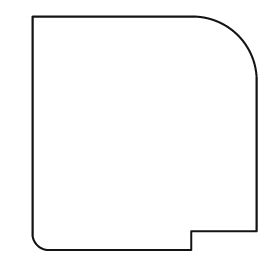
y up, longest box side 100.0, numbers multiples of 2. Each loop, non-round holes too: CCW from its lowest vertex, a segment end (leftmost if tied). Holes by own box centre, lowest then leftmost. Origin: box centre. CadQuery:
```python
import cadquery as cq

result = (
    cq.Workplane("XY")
    .moveTo(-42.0, -50.0)
    .lineTo(20.0, -50.0)
    .lineTo(20.0, -42.0)
    .lineTo(48.0, -42.0)
    .lineTo(48.0, 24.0)
    .threePointArc((40.0, 42.0), (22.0, 50.0))
    .lineTo(-48.0, 50.0)
    .lineTo(-48.0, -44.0)
    .threePointArc((-46.0, -48.0), (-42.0, -50.0))
    .close()
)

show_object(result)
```